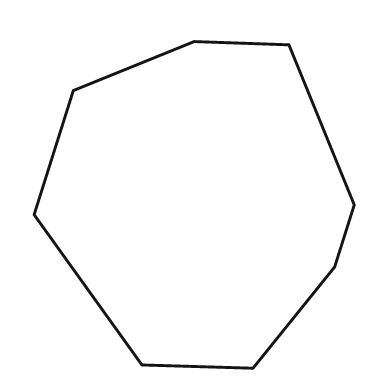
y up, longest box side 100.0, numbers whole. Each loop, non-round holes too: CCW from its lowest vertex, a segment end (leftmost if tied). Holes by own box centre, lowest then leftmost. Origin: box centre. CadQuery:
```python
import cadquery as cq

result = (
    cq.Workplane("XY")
    .moveTo(18.0, -50.0)
    .lineTo(43.0, -19.0)
    .lineTo(49.0, 0.0)
    .lineTo(29.0, 49.0)
    .lineTo(0.0, 50.0)
    .lineTo(-37.0, 35.0)
    .lineTo(-49.0, -3.0)
    .lineTo(-16.0, -49.0)
    .close()
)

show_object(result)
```